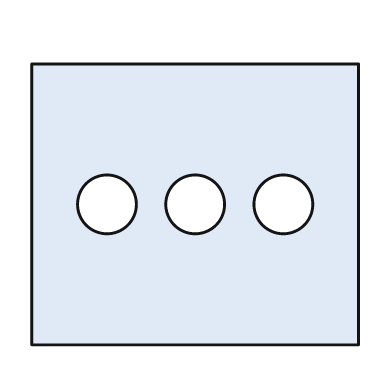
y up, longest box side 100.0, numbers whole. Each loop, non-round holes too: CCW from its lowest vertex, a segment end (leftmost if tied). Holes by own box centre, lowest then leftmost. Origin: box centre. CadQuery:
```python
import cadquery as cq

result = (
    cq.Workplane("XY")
    .moveTo(-50.0, -43.0)
    .lineTo(50.0, -43.0)
    .lineTo(50.0, 43.0)
    .lineTo(-50.0, 43.0)
    .close()
    .moveTo(-27.0, 0.0)
    .circle(9.0)
    .moveTo(0.0, 0.0)
    .circle(9.0)
    .moveTo(27.0, 0.0)
    .circle(9.0)
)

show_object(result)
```